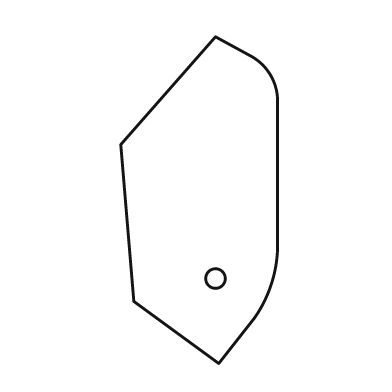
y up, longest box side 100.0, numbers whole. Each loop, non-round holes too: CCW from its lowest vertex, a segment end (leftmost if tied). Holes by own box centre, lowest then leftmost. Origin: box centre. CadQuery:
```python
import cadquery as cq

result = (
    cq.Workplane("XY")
    .moveTo(6.0, -50.0)
    .lineTo(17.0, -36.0)
    .threePointArc((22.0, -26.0), (24.0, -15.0))
    .lineTo(24.0, 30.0)
    .threePointArc((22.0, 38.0), (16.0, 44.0))
    .lineTo(5.0, 50.0)
    .lineTo(-24.0, 17.0)
    .lineTo(-20.0, -31.0)
    .close()
    .moveTo(5.0, -24.0)
    .circle(3.0)
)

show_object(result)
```